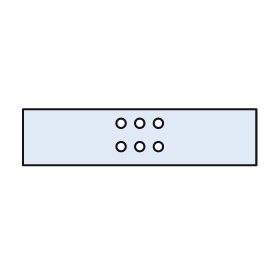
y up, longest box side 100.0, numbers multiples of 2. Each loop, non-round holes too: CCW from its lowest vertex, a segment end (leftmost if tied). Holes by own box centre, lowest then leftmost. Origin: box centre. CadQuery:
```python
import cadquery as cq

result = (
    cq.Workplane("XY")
    .moveTo(-50.0, -12.0)
    .lineTo(50.0, -12.0)
    .lineTo(50.0, 12.0)
    .lineTo(-50.0, 12.0)
    .close()
    .moveTo(-8.0, -4.0)
    .circle(2.0)
    .moveTo(0.0, -4.0)
    .circle(2.0)
    .moveTo(8.0, -4.0)
    .circle(2.0)
    .moveTo(-8.0, 6.0)
    .circle(2.0)
    .moveTo(0.0, 6.0)
    .circle(2.0)
    .moveTo(8.0, 6.0)
    .circle(2.0)
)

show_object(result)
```